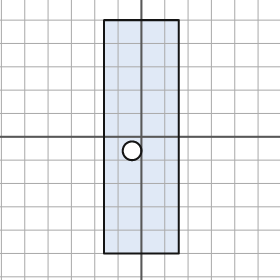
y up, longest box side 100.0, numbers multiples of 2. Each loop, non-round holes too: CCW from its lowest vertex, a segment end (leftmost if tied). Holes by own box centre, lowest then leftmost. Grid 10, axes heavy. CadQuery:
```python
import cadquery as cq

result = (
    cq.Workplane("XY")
    .moveTo(-16.0, -50.0)
    .lineTo(16.0, -50.0)
    .lineTo(16.0, 50.0)
    .lineTo(-16.0, 50.0)
    .close()
    .moveTo(-4.0, -6.0)
    .circle(4.0)
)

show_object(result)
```